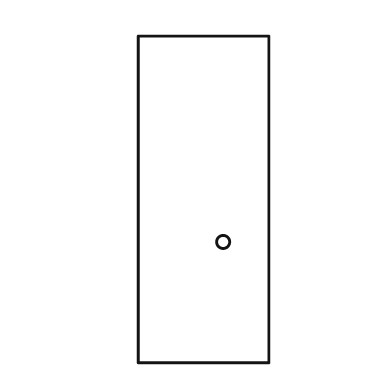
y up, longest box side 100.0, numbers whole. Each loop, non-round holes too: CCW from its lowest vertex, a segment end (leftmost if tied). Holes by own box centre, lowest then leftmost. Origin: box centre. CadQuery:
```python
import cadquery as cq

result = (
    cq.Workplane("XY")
    .moveTo(-20.0, -50.0)
    .lineTo(20.0, -50.0)
    .lineTo(20.0, 50.0)
    .lineTo(-20.0, 50.0)
    .close()
    .moveTo(6.0, -13.0)
    .circle(2.0)
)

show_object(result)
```